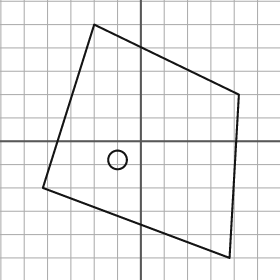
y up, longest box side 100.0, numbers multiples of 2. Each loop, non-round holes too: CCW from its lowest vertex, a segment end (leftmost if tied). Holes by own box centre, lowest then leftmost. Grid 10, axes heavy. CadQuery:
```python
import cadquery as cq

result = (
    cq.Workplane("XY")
    .moveTo(38.0, -50.0)
    .lineTo(42.0, 20.0)
    .lineTo(-20.0, 50.0)
    .lineTo(-42.0, -20.0)
    .close()
    .moveTo(-10.0, -8.0)
    .circle(4.0)
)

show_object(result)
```